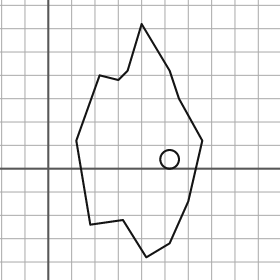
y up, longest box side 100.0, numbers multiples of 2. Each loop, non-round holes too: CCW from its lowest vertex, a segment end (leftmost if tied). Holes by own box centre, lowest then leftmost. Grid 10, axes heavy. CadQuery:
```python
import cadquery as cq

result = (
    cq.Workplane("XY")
    .moveTo(42.0, -38.0)
    .lineTo(52.0, -32.0)
    .lineTo(60.0, -14.0)
    .lineTo(66.0, 12.0)
    .lineTo(56.0, 30.0)
    .lineTo(52.0, 42.0)
    .lineTo(40.0, 62.0)
    .lineTo(34.0, 42.0)
    .lineTo(30.0, 38.0)
    .lineTo(22.0, 40.0)
    .lineTo(12.0, 12.0)
    .lineTo(18.0, -24.0)
    .lineTo(32.0, -22.0)
    .close()
    .moveTo(52.0, 4.0)
    .circle(4.0)
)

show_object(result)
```